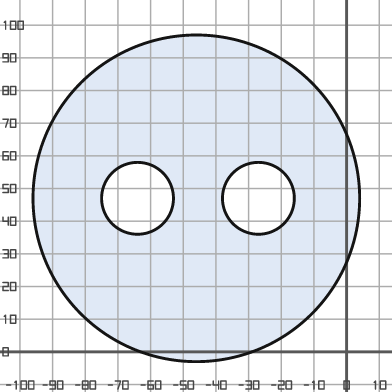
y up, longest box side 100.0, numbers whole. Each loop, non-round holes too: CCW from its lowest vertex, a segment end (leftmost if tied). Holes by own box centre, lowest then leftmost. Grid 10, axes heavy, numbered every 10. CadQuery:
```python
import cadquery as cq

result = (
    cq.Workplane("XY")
    .moveTo(-46.0, 47.0)
    .circle(50.0)
    .moveTo(-64.0, 47.0)
    .circle(11.0)
    .moveTo(-27.0, 47.0)
    .circle(11.0)
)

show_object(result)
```